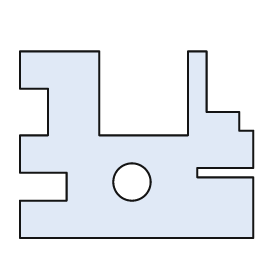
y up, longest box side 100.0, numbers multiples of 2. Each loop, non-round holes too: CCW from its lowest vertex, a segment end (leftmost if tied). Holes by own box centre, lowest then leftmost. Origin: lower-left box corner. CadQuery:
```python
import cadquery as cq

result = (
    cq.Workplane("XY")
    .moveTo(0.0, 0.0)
    .lineTo(100.0, 0.0)
    .lineTo(100.0, 26.0)
    .lineTo(76.0, 26.0)
    .lineTo(76.0, 30.0)
    .lineTo(100.0, 30.0)
    .lineTo(100.0, 46.0)
    .lineTo(94.0, 46.0)
    .lineTo(94.0, 54.0)
    .lineTo(80.0, 54.0)
    .lineTo(80.0, 80.0)
    .lineTo(72.0, 80.0)
    .lineTo(72.0, 44.0)
    .lineTo(34.0, 44.0)
    .lineTo(34.0, 80.0)
    .lineTo(0.0, 80.0)
    .lineTo(0.0, 64.0)
    .lineTo(12.0, 64.0)
    .lineTo(12.0, 44.0)
    .lineTo(0.0, 44.0)
    .lineTo(0.0, 28.0)
    .lineTo(20.0, 28.0)
    .lineTo(20.0, 16.0)
    .lineTo(0.0, 16.0)
    .close()
    .moveTo(48.0, 24.0)
    .circle(8.0)
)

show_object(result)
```